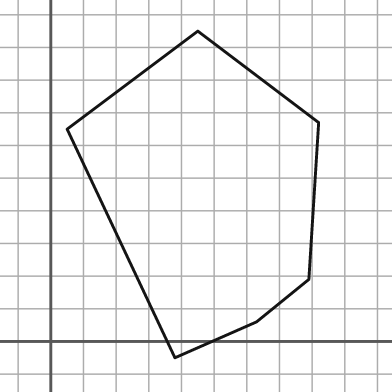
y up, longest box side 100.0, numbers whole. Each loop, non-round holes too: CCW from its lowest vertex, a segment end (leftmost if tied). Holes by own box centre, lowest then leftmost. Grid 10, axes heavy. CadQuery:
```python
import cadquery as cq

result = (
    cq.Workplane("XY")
    .moveTo(38.0, -5.0)
    .lineTo(63.0, 6.0)
    .lineTo(79.0, 19.0)
    .lineTo(82.0, 67.0)
    .lineTo(45.0, 95.0)
    .lineTo(5.0, 65.0)
    .close()
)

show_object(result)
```